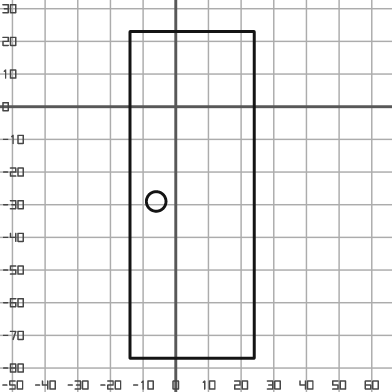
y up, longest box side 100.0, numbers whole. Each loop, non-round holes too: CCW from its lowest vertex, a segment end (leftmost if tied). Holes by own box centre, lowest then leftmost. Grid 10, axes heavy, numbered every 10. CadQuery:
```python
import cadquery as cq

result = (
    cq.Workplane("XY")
    .moveTo(-14.0, -77.0)
    .lineTo(24.0, -77.0)
    .lineTo(24.0, 23.0)
    .lineTo(-14.0, 23.0)
    .close()
    .moveTo(-6.0, -29.0)
    .circle(3.0)
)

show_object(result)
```